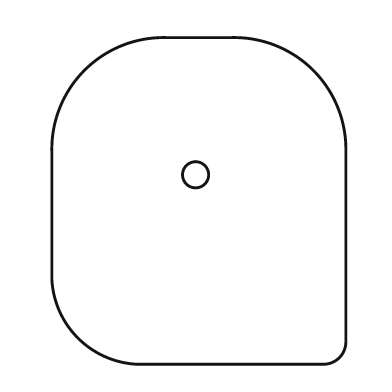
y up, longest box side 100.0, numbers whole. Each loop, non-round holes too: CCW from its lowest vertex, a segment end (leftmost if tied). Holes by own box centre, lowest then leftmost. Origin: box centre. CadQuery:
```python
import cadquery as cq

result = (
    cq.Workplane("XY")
    .moveTo(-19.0, -50.0)
    .lineTo(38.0, -50.0)
    .threePointArc((43.0, -48.0), (45.0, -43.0))
    .lineTo(45.0, 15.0)
    .threePointArc((35.0, 40.0), (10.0, 50.0))
    .lineTo(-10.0, 50.0)
    .threePointArc((-35.0, 40.0), (-45.0, 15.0))
    .lineTo(-45.0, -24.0)
    .threePointArc((-37.0, -42.0), (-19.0, -50.0))
    .close()
    .moveTo(-1.0, 8.0)
    .circle(4.0)
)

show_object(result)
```